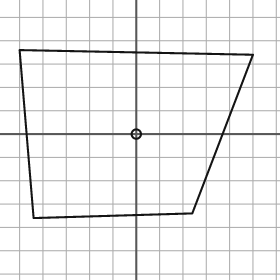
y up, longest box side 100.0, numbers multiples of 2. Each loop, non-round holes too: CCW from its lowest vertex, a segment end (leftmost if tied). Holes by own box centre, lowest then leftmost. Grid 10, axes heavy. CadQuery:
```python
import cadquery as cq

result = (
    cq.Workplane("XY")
    .moveTo(-44.0, -36.0)
    .lineTo(24.0, -34.0)
    .lineTo(50.0, 34.0)
    .lineTo(-50.0, 36.0)
    .close()
    .moveTo(0.0, 0.0)
    .circle(2.0)
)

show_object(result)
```